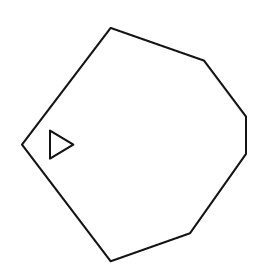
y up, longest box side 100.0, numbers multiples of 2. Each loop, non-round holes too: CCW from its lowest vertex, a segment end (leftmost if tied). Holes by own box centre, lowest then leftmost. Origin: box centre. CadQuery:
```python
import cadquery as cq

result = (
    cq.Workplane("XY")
    .moveTo(-10.0, -50.0)
    .lineTo(24.0, -38.0)
    .lineTo(48.0, -4.0)
    .lineTo(48.0, 12.0)
    .lineTo(30.0, 36.0)
    .lineTo(-10.0, 50.0)
    .lineTo(-48.0, 0.0)
    .close()
    .moveTo(-36.0, -6.0)
    .lineTo(-26.0, 0.0)
    .lineTo(-36.0, 6.0)
    .close()
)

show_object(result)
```